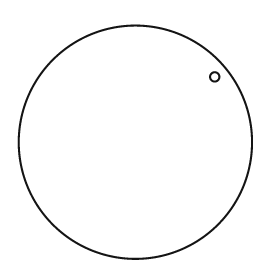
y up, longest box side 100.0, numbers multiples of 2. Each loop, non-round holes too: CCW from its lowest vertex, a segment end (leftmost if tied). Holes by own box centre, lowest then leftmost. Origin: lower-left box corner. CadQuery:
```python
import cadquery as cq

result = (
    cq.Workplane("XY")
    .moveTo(50.0, 50.0)
    .circle(50.0)
    .moveTo(84.0, 78.0)
    .circle(2.0)
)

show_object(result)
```